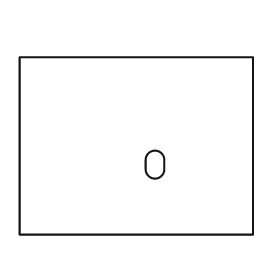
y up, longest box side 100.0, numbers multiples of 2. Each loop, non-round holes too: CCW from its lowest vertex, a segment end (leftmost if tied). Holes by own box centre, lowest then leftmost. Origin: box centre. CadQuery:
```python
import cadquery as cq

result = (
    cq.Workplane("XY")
    .moveTo(-50.0, -38.0)
    .lineTo(50.0, -38.0)
    .lineTo(50.0, 38.0)
    .lineTo(-50.0, 38.0)
    .close()
    .moveTo(4.0, -10.0)
    .threePointArc((8.0, -14.0), (12.0, -10.0))
    .lineTo(12.0, -6.0)
    .threePointArc((8.0, -2.0), (4.0, -6.0))
    .close()
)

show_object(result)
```